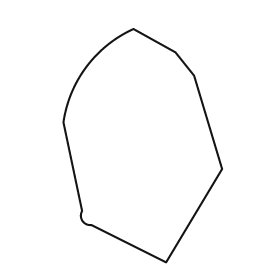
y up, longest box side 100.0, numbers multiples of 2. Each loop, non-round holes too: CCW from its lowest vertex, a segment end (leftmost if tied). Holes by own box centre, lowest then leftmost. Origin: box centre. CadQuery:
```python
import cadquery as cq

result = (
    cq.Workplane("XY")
    .moveTo(10.0, -50.0)
    .lineTo(34.0, -10.0)
    .lineTo(22.0, 30.0)
    .lineTo(14.0, 40.0)
    .lineTo(-4.0, 50.0)
    .threePointArc((-24.0, 34.0), (-34.0, 10.0))
    .lineTo(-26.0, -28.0)
    .threePointArc((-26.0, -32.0), (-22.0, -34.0))
    .close()
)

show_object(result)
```